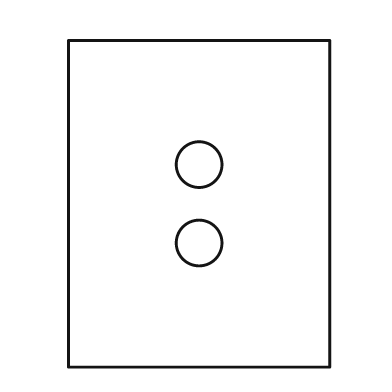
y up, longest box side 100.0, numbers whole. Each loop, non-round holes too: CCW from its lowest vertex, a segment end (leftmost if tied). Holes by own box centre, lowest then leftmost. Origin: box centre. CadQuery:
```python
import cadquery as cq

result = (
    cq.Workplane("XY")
    .moveTo(-40.0, -50.0)
    .lineTo(40.0, -50.0)
    .lineTo(40.0, 50.0)
    .lineTo(-40.0, 50.0)
    .close()
    .moveTo(0.0, -12.0)
    .circle(7.0)
    .moveTo(0.0, 12.0)
    .circle(7.0)
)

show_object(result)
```